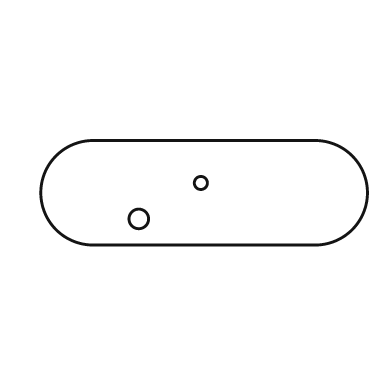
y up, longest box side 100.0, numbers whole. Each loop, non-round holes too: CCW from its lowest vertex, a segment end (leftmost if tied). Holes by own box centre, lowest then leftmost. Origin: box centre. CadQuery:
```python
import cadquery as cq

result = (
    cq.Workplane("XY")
    .moveTo(-34.0, -16.0)
    .lineTo(34.0, -16.0)
    .threePointArc((50.0, 0.0), (34.0, 16.0))
    .lineTo(-34.0, 16.0)
    .threePointArc((-50.0, 0.0), (-34.0, -16.0))
    .close()
    .moveTo(-20.0, -8.0)
    .circle(3.0)
    .moveTo(-1.0, 3.0)
    .circle(2.0)
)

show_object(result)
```